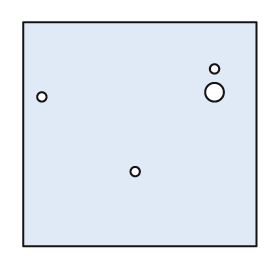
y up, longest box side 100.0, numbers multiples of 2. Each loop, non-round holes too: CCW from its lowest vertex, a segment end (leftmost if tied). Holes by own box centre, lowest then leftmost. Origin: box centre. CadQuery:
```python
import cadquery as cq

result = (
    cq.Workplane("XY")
    .moveTo(-50.0, -48.0)
    .lineTo(50.0, -48.0)
    .lineTo(50.0, 48.0)
    .lineTo(-50.0, 48.0)
    .close()
    .moveTo(-2.0, -16.0)
    .circle(2.0)
    .moveTo(-42.0, 16.0)
    .circle(2.0)
    .moveTo(32.0, 18.0)
    .circle(4.0)
    .moveTo(32.0, 28.0)
    .circle(2.0)
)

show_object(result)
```